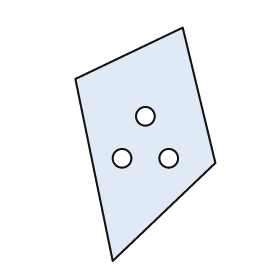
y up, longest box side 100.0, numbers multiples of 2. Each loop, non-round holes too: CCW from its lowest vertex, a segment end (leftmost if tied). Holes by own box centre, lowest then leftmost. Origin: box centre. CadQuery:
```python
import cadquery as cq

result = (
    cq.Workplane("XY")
    .moveTo(-14.0, -50.0)
    .lineTo(30.0, -8.0)
    .lineTo(16.0, 50.0)
    .lineTo(-30.0, 28.0)
    .close()
    .moveTo(-10.0, -6.0)
    .circle(4.0)
    .moveTo(10.0, -6.0)
    .circle(4.0)
    .moveTo(0.0, 12.0)
    .circle(4.0)
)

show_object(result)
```